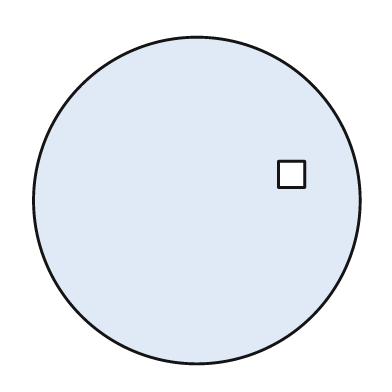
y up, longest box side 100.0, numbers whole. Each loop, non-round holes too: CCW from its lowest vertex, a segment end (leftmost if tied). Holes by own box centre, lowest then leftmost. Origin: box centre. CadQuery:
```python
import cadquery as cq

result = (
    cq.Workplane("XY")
    .moveTo(0.0, 0.0)
    .circle(50.0)
    .moveTo(25.0, 4.0)
    .lineTo(33.0, 4.0)
    .lineTo(33.0, 12.0)
    .lineTo(25.0, 12.0)
    .close()
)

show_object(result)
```